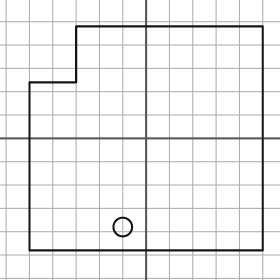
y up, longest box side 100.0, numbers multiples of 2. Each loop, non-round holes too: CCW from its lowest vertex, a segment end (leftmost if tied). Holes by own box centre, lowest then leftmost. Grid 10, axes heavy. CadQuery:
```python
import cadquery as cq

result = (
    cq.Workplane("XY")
    .moveTo(-50.0, -48.0)
    .lineTo(50.0, -48.0)
    .lineTo(50.0, 48.0)
    .lineTo(-30.0, 48.0)
    .lineTo(-30.0, 24.0)
    .lineTo(-50.0, 24.0)
    .close()
    .moveTo(-10.0, -38.0)
    .circle(4.0)
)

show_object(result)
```